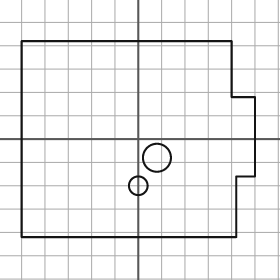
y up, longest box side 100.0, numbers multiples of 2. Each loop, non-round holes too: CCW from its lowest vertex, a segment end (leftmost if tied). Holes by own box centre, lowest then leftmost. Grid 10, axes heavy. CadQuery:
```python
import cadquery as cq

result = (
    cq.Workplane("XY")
    .moveTo(-50.0, -42.0)
    .lineTo(42.0, -42.0)
    .lineTo(42.0, -16.0)
    .lineTo(50.0, -16.0)
    .lineTo(50.0, 18.0)
    .lineTo(40.0, 18.0)
    .lineTo(40.0, 42.0)
    .lineTo(-50.0, 42.0)
    .close()
    .moveTo(0.0, -20.0)
    .circle(4.0)
    .moveTo(8.0, -8.0)
    .circle(6.0)
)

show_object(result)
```